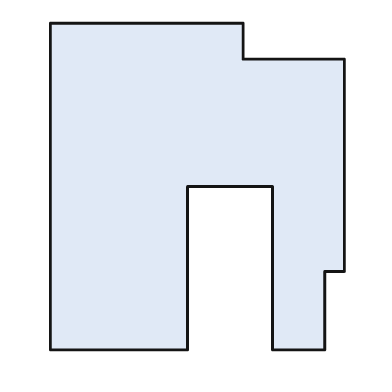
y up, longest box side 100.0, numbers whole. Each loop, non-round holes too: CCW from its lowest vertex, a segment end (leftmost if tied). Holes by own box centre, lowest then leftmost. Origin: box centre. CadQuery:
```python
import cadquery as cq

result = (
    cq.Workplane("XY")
    .moveTo(-45.0, -50.0)
    .lineTo(-3.0, -50.0)
    .lineTo(-3.0, 0.0)
    .lineTo(23.0, 0.0)
    .lineTo(23.0, -50.0)
    .lineTo(39.0, -50.0)
    .lineTo(39.0, -26.0)
    .lineTo(45.0, -26.0)
    .lineTo(45.0, 39.0)
    .lineTo(14.0, 39.0)
    .lineTo(14.0, 50.0)
    .lineTo(-45.0, 50.0)
    .close()
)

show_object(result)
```